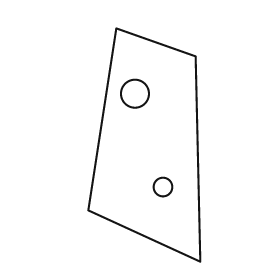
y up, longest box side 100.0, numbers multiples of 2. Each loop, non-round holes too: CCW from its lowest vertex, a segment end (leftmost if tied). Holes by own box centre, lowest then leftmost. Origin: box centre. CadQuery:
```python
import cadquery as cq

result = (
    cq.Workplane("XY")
    .moveTo(24.0, -50.0)
    .lineTo(22.0, 38.0)
    .lineTo(-12.0, 50.0)
    .lineTo(-24.0, -28.0)
    .close()
    .moveTo(8.0, -18.0)
    .circle(4.0)
    .moveTo(-4.0, 22.0)
    .circle(6.0)
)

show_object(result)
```